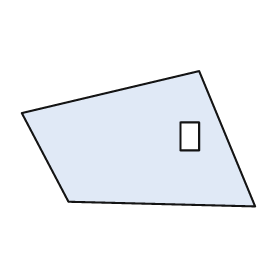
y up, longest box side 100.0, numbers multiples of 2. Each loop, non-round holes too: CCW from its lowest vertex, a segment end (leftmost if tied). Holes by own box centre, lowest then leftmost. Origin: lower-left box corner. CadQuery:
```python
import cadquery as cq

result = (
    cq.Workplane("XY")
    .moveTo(100.0, 0.0)
    .lineTo(76.0, 58.0)
    .lineTo(0.0, 40.0)
    .lineTo(20.0, 2.0)
    .close()
    .moveTo(68.0, 24.0)
    .lineTo(76.0, 24.0)
    .lineTo(76.0, 36.0)
    .lineTo(68.0, 36.0)
    .close()
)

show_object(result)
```